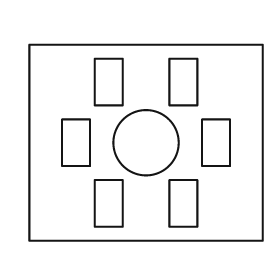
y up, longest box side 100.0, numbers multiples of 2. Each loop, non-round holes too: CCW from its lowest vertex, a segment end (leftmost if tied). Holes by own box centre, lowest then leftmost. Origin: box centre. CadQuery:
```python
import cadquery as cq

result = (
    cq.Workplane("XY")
    .moveTo(-50.0, -42.0)
    .lineTo(50.0, -42.0)
    .lineTo(50.0, 42.0)
    .lineTo(-50.0, 42.0)
    .close()
    .moveTo(-22.0, -36.0)
    .lineTo(-10.0, -36.0)
    .lineTo(-10.0, -16.0)
    .lineTo(-22.0, -16.0)
    .close()
    .moveTo(10.0, -36.0)
    .lineTo(22.0, -36.0)
    .lineTo(22.0, -16.0)
    .lineTo(10.0, -16.0)
    .close()
    .moveTo(-36.0, -10.0)
    .lineTo(-24.0, -10.0)
    .lineTo(-24.0, 10.0)
    .lineTo(-36.0, 10.0)
    .close()
    .moveTo(0.0, 0.0)
    .circle(14.0)
    .moveTo(24.0, -10.0)
    .lineTo(36.0, -10.0)
    .lineTo(36.0, 10.0)
    .lineTo(24.0, 10.0)
    .close()
    .moveTo(-22.0, 16.0)
    .lineTo(-10.0, 16.0)
    .lineTo(-10.0, 36.0)
    .lineTo(-22.0, 36.0)
    .close()
    .moveTo(10.0, 16.0)
    .lineTo(22.0, 16.0)
    .lineTo(22.0, 36.0)
    .lineTo(10.0, 36.0)
    .close()
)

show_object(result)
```